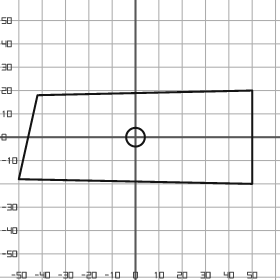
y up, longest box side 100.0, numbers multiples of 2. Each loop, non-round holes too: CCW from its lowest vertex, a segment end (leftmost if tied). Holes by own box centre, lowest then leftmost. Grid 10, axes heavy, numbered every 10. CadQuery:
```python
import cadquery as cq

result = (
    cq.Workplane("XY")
    .moveTo(50.0, -20.0)
    .lineTo(50.0, 20.0)
    .lineTo(-42.0, 18.0)
    .lineTo(-50.0, -18.0)
    .close()
    .moveTo(0.0, 0.0)
    .circle(4.0)
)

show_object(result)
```